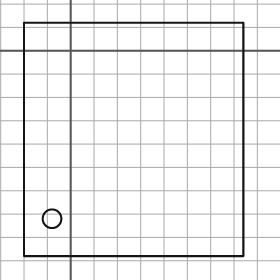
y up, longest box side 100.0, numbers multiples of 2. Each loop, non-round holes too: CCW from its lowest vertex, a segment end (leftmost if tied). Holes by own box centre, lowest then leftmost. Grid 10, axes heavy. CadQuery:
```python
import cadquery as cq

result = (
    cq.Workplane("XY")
    .moveTo(-20.0, -88.0)
    .lineTo(74.0, -88.0)
    .lineTo(74.0, 12.0)
    .lineTo(-20.0, 12.0)
    .close()
    .moveTo(-8.0, -72.0)
    .circle(4.0)
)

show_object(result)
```